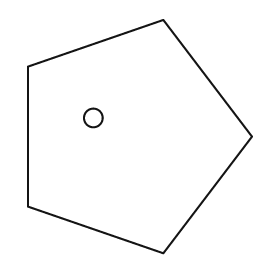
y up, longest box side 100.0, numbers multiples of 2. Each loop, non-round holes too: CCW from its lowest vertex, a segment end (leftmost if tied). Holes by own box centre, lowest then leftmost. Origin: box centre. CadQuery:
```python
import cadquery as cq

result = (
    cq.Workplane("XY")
    .moveTo(10.0, -50.0)
    .lineTo(48.0, 0.0)
    .lineTo(10.0, 50.0)
    .lineTo(-48.0, 30.0)
    .lineTo(-48.0, -30.0)
    .close()
    .moveTo(-20.0, 8.0)
    .circle(4.0)
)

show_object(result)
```